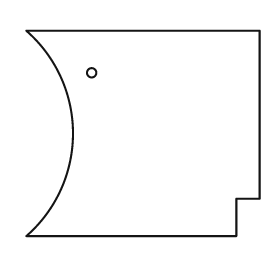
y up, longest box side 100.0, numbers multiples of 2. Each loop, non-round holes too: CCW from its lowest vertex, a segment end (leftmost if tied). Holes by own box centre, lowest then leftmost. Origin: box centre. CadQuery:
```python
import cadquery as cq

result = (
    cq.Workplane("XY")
    .moveTo(-50.0, -44.0)
    .lineTo(40.0, -44.0)
    .lineTo(40.0, -28.0)
    .lineTo(50.0, -28.0)
    .lineTo(50.0, 44.0)
    .lineTo(-50.0, 44.0)
    .threePointArc((-30.0, 0.0), (-50.0, -44.0))
    .close()
    .moveTo(-22.0, 26.0)
    .circle(2.0)
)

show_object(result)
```